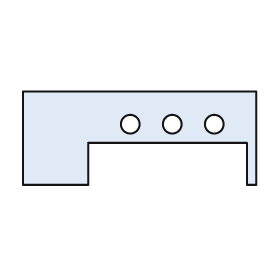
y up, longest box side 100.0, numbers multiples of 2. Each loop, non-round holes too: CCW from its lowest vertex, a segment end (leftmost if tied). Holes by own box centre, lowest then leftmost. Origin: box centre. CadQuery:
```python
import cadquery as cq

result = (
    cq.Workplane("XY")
    .moveTo(-50.0, -20.0)
    .lineTo(-22.0, -20.0)
    .lineTo(-22.0, -2.0)
    .lineTo(46.0, -2.0)
    .lineTo(46.0, -20.0)
    .lineTo(50.0, -20.0)
    .lineTo(50.0, 20.0)
    .lineTo(-50.0, 20.0)
    .close()
    .moveTo(-4.0, 6.0)
    .circle(4.0)
    .moveTo(14.0, 6.0)
    .circle(4.0)
    .moveTo(32.0, 6.0)
    .circle(4.0)
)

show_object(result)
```